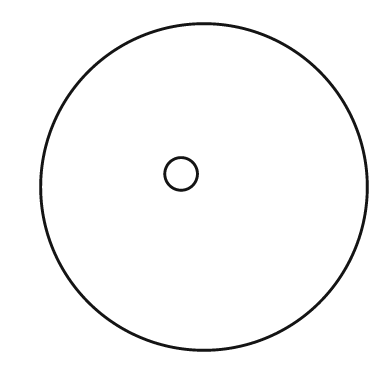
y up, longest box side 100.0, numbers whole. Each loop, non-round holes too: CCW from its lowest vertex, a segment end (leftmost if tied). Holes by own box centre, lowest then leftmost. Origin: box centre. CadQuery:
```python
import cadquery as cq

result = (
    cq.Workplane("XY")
    .moveTo(0.0, 0.0)
    .circle(50.0)
    .moveTo(-7.0, 4.0)
    .circle(5.0)
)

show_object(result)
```